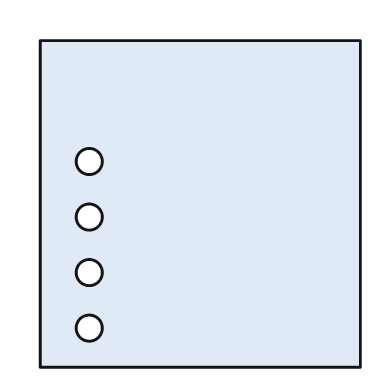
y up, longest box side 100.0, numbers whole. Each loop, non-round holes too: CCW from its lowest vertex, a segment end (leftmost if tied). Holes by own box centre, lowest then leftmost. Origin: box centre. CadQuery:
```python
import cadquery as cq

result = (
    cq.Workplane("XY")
    .moveTo(-49.0, -50.0)
    .lineTo(49.0, -50.0)
    .lineTo(49.0, 50.0)
    .lineTo(-49.0, 50.0)
    .close()
    .moveTo(-34.0, -38.0)
    .circle(4.0)
    .moveTo(-34.0, -21.0)
    .circle(4.0)
    .moveTo(-34.0, -4.0)
    .circle(4.0)
    .moveTo(-34.0, 13.0)
    .circle(4.0)
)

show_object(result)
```